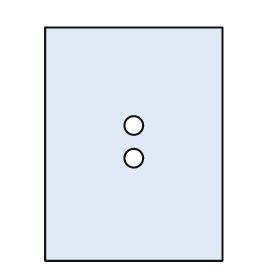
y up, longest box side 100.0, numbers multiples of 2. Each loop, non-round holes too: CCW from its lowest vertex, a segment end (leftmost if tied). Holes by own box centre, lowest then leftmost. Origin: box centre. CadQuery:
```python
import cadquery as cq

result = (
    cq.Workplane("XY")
    .moveTo(-38.0, -50.0)
    .lineTo(38.0, -50.0)
    .lineTo(38.0, 50.0)
    .lineTo(-38.0, 50.0)
    .close()
    .moveTo(0.0, -6.0)
    .circle(4.0)
    .moveTo(0.0, 8.0)
    .circle(4.0)
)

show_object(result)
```